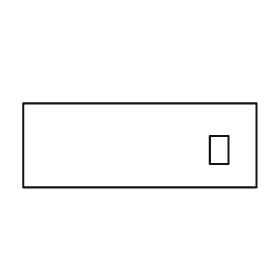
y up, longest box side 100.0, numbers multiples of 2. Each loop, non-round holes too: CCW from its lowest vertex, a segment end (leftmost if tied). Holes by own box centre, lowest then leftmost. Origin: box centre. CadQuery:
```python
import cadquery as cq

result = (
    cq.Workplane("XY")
    .moveTo(-50.0, -18.0)
    .lineTo(50.0, -18.0)
    .lineTo(50.0, 18.0)
    .lineTo(-50.0, 18.0)
    .close()
    .moveTo(30.0, -8.0)
    .lineTo(38.0, -8.0)
    .lineTo(38.0, 4.0)
    .lineTo(30.0, 4.0)
    .close()
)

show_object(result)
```